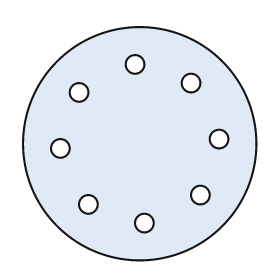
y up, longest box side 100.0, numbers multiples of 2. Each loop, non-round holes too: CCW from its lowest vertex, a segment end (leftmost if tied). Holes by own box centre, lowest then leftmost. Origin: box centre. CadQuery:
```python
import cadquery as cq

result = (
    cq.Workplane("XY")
    .moveTo(0.0, 0.0)
    .circle(50.0)
    .moveTo(2.0, -34.0)
    .circle(4.0)
    .moveTo(-22.0, -26.0)
    .circle(4.0)
    .moveTo(26.0, -22.0)
    .circle(4.0)
    .moveTo(-34.0, -2.0)
    .circle(4.0)
    .moveTo(34.0, 2.0)
    .circle(4.0)
    .moveTo(-26.0, 22.0)
    .circle(4.0)
    .moveTo(22.0, 26.0)
    .circle(4.0)
    .moveTo(-2.0, 34.0)
    .circle(4.0)
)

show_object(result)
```